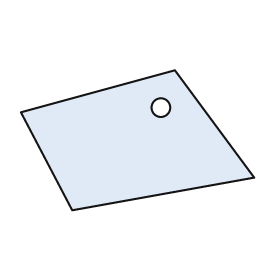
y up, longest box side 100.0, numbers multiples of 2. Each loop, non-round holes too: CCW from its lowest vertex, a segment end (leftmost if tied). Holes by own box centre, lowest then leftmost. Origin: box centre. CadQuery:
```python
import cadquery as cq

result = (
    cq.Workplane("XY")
    .moveTo(-28.0, -30.0)
    .lineTo(50.0, -16.0)
    .lineTo(16.0, 30.0)
    .lineTo(-50.0, 12.0)
    .close()
    .moveTo(10.0, 14.0)
    .circle(4.0)
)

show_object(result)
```